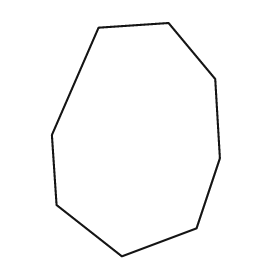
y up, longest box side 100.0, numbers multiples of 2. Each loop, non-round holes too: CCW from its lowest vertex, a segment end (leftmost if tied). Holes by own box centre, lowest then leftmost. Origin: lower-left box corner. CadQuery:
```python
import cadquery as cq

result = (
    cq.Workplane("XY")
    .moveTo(30.0, 0.0)
    .lineTo(62.0, 12.0)
    .lineTo(72.0, 42.0)
    .lineTo(70.0, 76.0)
    .lineTo(50.0, 100.0)
    .lineTo(20.0, 98.0)
    .lineTo(0.0, 52.0)
    .lineTo(2.0, 22.0)
    .close()
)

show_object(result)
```